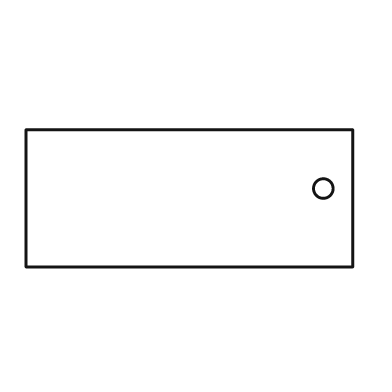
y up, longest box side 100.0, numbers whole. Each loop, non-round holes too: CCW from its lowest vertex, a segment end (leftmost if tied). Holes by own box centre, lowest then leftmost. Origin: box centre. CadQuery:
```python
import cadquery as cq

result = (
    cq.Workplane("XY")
    .moveTo(-50.0, -21.0)
    .lineTo(50.0, -21.0)
    .lineTo(50.0, 21.0)
    .lineTo(-50.0, 21.0)
    .close()
    .moveTo(41.0, 3.0)
    .circle(3.0)
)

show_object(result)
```